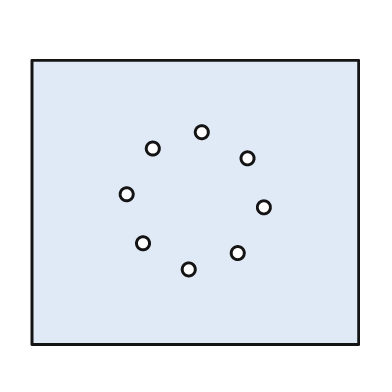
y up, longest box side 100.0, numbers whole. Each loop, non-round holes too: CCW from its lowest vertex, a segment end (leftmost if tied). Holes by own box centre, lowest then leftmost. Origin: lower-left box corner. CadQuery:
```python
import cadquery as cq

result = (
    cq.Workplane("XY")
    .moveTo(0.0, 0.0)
    .lineTo(100.0, 0.0)
    .lineTo(100.0, 87.0)
    .lineTo(0.0, 87.0)
    .close()
    .moveTo(48.0, 23.0)
    .circle(2.0)
    .moveTo(63.0, 28.0)
    .circle(2.0)
    .moveTo(34.0, 31.0)
    .circle(2.0)
    .moveTo(71.0, 42.0)
    .circle(2.0)
    .moveTo(29.0, 46.0)
    .circle(2.0)
    .moveTo(66.0, 57.0)
    .circle(2.0)
    .moveTo(37.0, 60.0)
    .circle(2.0)
    .moveTo(52.0, 65.0)
    .circle(2.0)
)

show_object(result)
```